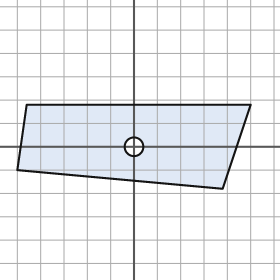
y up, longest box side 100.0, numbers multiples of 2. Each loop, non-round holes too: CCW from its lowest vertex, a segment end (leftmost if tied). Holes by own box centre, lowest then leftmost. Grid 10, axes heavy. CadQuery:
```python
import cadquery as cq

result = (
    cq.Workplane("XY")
    .moveTo(38.0, -18.0)
    .lineTo(50.0, 18.0)
    .lineTo(-46.0, 18.0)
    .lineTo(-50.0, -10.0)
    .close()
    .moveTo(0.0, 0.0)
    .circle(4.0)
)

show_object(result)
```